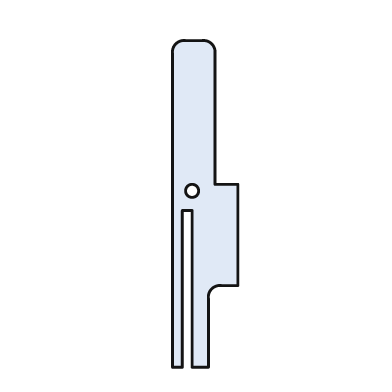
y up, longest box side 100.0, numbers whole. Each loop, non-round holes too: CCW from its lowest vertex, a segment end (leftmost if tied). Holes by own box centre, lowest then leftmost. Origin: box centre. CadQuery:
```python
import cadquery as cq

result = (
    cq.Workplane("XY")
    .moveTo(-10.0, -50.0)
    .lineTo(-7.0, -50.0)
    .lineTo(-7.0, -2.0)
    .lineTo(-4.0, -2.0)
    .lineTo(-4.0, -50.0)
    .lineTo(1.0, -50.0)
    .lineTo(1.0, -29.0)
    .threePointArc((2.0, -26.0), (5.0, -25.0))
    .lineTo(10.0, -25.0)
    .lineTo(10.0, 6.0)
    .lineTo(3.0, 6.0)
    .lineTo(3.0, 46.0)
    .threePointArc((2.0, 49.0), (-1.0, 50.0))
    .lineTo(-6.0, 50.0)
    .threePointArc((-9.0, 49.0), (-10.0, 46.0))
    .close()
    .moveTo(-4.0, 4.0)
    .circle(2.0)
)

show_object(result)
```